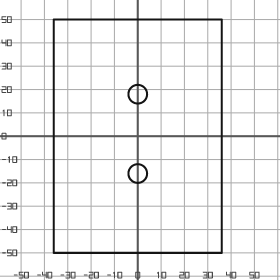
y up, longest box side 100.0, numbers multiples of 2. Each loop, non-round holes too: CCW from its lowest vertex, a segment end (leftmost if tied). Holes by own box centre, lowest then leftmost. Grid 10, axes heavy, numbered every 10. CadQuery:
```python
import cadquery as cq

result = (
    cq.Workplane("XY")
    .moveTo(-36.0, -50.0)
    .lineTo(36.0, -50.0)
    .lineTo(36.0, 50.0)
    .lineTo(-36.0, 50.0)
    .close()
    .moveTo(0.0, -16.0)
    .circle(4.0)
    .moveTo(0.0, 18.0)
    .circle(4.0)
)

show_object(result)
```